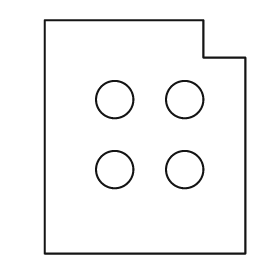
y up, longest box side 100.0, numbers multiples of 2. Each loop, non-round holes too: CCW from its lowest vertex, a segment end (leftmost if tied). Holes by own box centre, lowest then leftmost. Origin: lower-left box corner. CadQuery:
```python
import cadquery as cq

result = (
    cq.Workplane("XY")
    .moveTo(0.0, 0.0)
    .lineTo(86.0, 0.0)
    .lineTo(86.0, 84.0)
    .lineTo(68.0, 84.0)
    .lineTo(68.0, 100.0)
    .lineTo(0.0, 100.0)
    .close()
    .moveTo(30.0, 36.0)
    .circle(8.0)
    .moveTo(60.0, 36.0)
    .circle(8.0)
    .moveTo(30.0, 66.0)
    .circle(8.0)
    .moveTo(60.0, 66.0)
    .circle(8.0)
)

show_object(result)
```